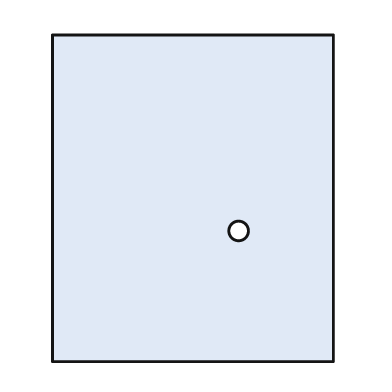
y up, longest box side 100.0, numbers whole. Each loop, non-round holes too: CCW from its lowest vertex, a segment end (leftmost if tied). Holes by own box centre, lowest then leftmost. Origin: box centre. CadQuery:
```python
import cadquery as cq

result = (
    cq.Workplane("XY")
    .moveTo(-43.0, -50.0)
    .lineTo(43.0, -50.0)
    .lineTo(43.0, 50.0)
    .lineTo(-43.0, 50.0)
    .close()
    .moveTo(14.0, -10.0)
    .circle(3.0)
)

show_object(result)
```